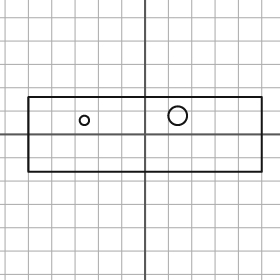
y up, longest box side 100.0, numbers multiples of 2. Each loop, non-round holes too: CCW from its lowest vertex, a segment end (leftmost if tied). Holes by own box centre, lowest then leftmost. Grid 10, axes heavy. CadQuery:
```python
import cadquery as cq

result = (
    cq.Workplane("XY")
    .moveTo(-50.0, -16.0)
    .lineTo(50.0, -16.0)
    .lineTo(50.0, 16.0)
    .lineTo(-50.0, 16.0)
    .close()
    .moveTo(-26.0, 6.0)
    .circle(2.0)
    .moveTo(14.0, 8.0)
    .circle(4.0)
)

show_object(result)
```